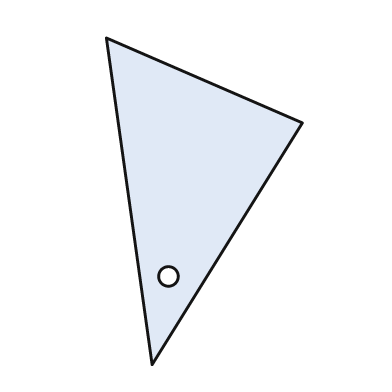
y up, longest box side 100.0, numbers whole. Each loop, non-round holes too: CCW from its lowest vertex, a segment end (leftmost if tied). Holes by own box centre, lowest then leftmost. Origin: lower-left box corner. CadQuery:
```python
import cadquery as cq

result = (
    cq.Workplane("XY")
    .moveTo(14.0, 0.0)
    .lineTo(60.0, 74.0)
    .lineTo(0.0, 100.0)
    .close()
    .moveTo(19.0, 27.0)
    .circle(3.0)
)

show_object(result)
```